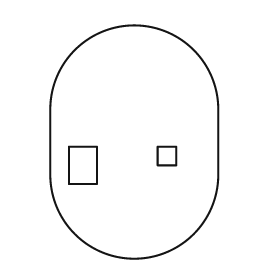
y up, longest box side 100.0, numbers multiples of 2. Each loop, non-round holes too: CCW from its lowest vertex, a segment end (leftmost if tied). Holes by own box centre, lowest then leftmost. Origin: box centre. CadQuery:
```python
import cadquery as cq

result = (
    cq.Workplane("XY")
    .moveTo(-36.0, -14.0)
    .threePointArc((0.0, -50.0), (36.0, -14.0))
    .lineTo(36.0, 14.0)
    .threePointArc((0.0, 50.0), (-36.0, 14.0))
    .close()
    .moveTo(-28.0, -18.0)
    .lineTo(-16.0, -18.0)
    .lineTo(-16.0, -2.0)
    .lineTo(-28.0, -2.0)
    .close()
    .moveTo(10.0, -10.0)
    .lineTo(18.0, -10.0)
    .lineTo(18.0, -2.0)
    .lineTo(10.0, -2.0)
    .close()
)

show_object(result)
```